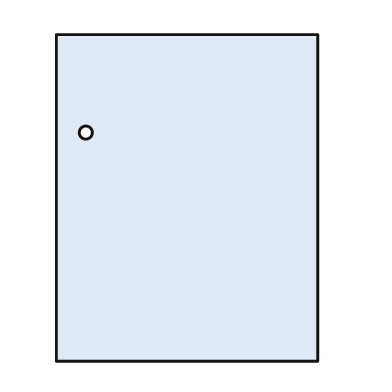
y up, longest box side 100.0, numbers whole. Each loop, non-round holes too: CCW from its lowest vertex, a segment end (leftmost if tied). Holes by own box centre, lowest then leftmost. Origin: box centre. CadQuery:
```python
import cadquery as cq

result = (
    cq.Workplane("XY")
    .moveTo(-40.0, -50.0)
    .lineTo(40.0, -50.0)
    .lineTo(40.0, 50.0)
    .lineTo(-40.0, 50.0)
    .close()
    .moveTo(-31.0, 20.0)
    .circle(2.0)
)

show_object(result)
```